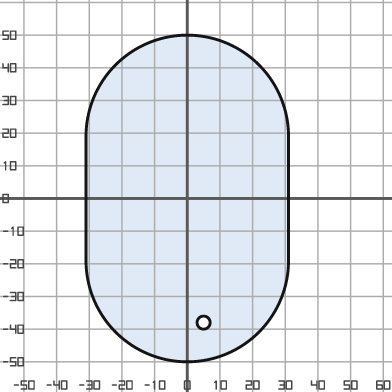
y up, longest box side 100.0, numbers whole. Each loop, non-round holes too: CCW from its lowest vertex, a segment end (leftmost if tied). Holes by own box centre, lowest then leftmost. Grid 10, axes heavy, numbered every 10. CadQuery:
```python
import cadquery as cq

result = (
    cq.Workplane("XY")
    .moveTo(-31.0, -19.0)
    .threePointArc((0.0, -50.0), (31.0, -19.0))
    .lineTo(31.0, 19.0)
    .threePointArc((0.0, 50.0), (-31.0, 19.0))
    .close()
    .moveTo(5.0, -38.0)
    .circle(2.0)
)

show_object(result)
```